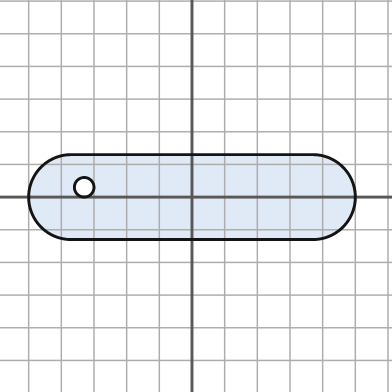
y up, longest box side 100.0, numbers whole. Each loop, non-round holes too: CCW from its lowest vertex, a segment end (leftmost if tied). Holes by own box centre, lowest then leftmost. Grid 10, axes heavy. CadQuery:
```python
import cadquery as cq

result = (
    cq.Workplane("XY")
    .moveTo(-37.0, -13.0)
    .lineTo(37.0, -13.0)
    .threePointArc((50.0, 0.0), (37.0, 13.0))
    .lineTo(-37.0, 13.0)
    .threePointArc((-50.0, 0.0), (-37.0, -13.0))
    .close()
    .moveTo(-33.0, 3.0)
    .circle(3.0)
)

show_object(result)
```